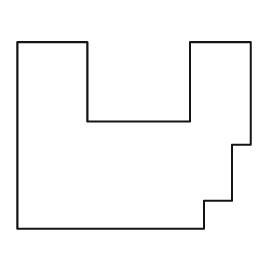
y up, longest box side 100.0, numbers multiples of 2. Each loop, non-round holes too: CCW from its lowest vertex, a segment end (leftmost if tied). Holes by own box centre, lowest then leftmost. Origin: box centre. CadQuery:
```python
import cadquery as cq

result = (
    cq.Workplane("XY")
    .moveTo(-50.0, -40.0)
    .lineTo(30.0, -40.0)
    .lineTo(30.0, -28.0)
    .lineTo(42.0, -28.0)
    .lineTo(42.0, -4.0)
    .lineTo(50.0, -4.0)
    .lineTo(50.0, 40.0)
    .lineTo(24.0, 40.0)
    .lineTo(24.0, 6.0)
    .lineTo(-20.0, 6.0)
    .lineTo(-20.0, 40.0)
    .lineTo(-50.0, 40.0)
    .close()
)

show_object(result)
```